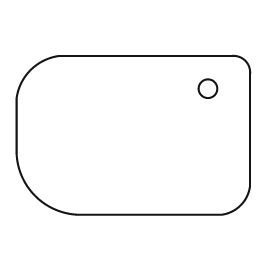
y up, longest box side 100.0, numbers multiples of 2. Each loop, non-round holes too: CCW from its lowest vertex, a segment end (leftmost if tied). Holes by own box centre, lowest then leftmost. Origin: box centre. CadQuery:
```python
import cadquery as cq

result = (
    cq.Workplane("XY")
    .moveTo(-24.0, -34.0)
    .lineTo(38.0, -34.0)
    .threePointArc((46.0, -30.0), (50.0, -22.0))
    .lineTo(50.0, 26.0)
    .threePointArc((48.0, 32.0), (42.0, 34.0))
    .lineTo(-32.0, 34.0)
    .threePointArc((-44.0, 28.0), (-50.0, 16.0))
    .lineTo(-50.0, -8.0)
    .threePointArc((-42.0, -26.0), (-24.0, -34.0))
    .close()
    .moveTo(32.0, 20.0)
    .circle(4.0)
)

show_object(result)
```